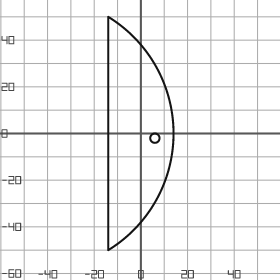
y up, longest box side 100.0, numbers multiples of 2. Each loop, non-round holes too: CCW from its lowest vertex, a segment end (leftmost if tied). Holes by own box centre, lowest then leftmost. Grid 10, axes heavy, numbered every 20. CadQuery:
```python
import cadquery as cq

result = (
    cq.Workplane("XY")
    .moveTo(-14.0, -50.0)
    .threePointArc((14.0, 0.0), (-14.0, 50.0))
    .close()
    .moveTo(6.0, -2.0)
    .circle(2.0)
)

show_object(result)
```